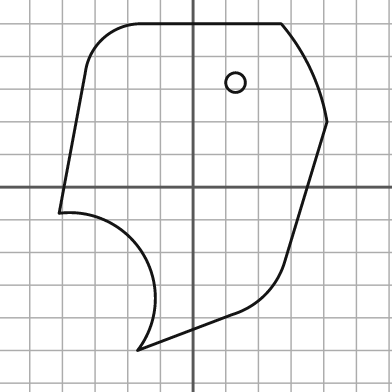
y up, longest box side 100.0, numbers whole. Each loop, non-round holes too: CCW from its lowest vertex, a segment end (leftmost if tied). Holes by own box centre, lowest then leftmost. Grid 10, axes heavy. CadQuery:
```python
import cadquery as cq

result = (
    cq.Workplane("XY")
    .moveTo(-17.0, -50.0)
    .lineTo(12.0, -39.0)
    .threePointArc((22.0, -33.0), (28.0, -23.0))
    .lineTo(41.0, 20.0)
    .threePointArc((36.0, 36.0), (27.0, 50.0))
    .lineTo(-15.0, 50.0)
    .threePointArc((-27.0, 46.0), (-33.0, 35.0))
    .lineTo(-41.0, -8.0)
    .threePointArc((-15.0, -21.0), (-17.0, -50.0))
    .close()
    .moveTo(13.0, 32.0)
    .circle(3.0)
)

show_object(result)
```